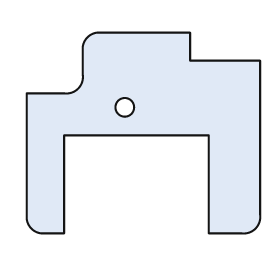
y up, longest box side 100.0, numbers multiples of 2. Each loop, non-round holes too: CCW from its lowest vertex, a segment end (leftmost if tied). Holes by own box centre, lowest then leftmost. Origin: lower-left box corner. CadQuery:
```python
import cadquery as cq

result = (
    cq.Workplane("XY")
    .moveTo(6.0, 0.0)
    .lineTo(16.0, 0.0)
    .lineTo(16.0, 42.0)
    .lineTo(78.0, 42.0)
    .lineTo(78.0, 0.0)
    .lineTo(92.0, 0.0)
    .threePointArc((98.0, 2.0), (100.0, 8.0))
    .lineTo(100.0, 74.0)
    .lineTo(70.0, 74.0)
    .lineTo(70.0, 86.0)
    .lineTo(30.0, 86.0)
    .threePointArc((26.0, 84.0), (24.0, 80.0))
    .lineTo(24.0, 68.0)
    .threePointArc((22.0, 62.0), (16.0, 60.0))
    .lineTo(0.0, 60.0)
    .lineTo(0.0, 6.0)
    .threePointArc((2.0, 2.0), (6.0, 0.0))
    .close()
    .moveTo(42.0, 54.0)
    .circle(4.0)
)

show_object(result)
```